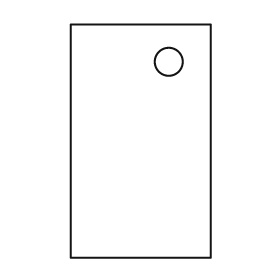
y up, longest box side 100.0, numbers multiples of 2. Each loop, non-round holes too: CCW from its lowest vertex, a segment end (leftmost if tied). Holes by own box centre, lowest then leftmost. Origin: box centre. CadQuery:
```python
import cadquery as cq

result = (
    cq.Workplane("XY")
    .moveTo(-30.0, -50.0)
    .lineTo(30.0, -50.0)
    .lineTo(30.0, 50.0)
    .lineTo(-30.0, 50.0)
    .close()
    .moveTo(12.0, 34.0)
    .circle(6.0)
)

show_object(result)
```